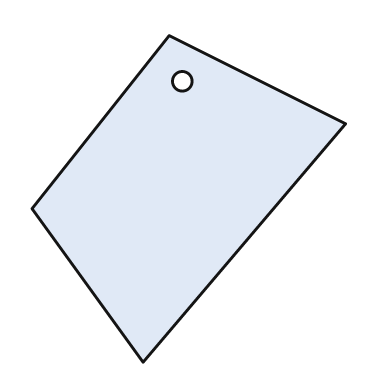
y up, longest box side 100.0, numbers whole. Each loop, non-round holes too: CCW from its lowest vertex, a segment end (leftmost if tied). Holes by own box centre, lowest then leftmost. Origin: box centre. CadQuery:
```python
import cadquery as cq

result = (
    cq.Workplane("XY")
    .moveTo(-14.0, -50.0)
    .lineTo(48.0, 23.0)
    .lineTo(-6.0, 50.0)
    .lineTo(-48.0, -3.0)
    .close()
    .moveTo(-2.0, 36.0)
    .circle(3.0)
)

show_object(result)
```